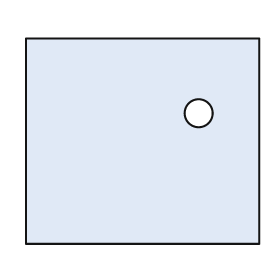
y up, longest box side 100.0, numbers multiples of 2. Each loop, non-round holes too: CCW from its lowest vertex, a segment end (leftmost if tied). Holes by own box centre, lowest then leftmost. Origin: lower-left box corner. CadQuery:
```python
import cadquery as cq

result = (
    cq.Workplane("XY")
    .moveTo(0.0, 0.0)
    .lineTo(100.0, 0.0)
    .lineTo(100.0, 88.0)
    .lineTo(0.0, 88.0)
    .close()
    .moveTo(74.0, 56.0)
    .circle(6.0)
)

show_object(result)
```